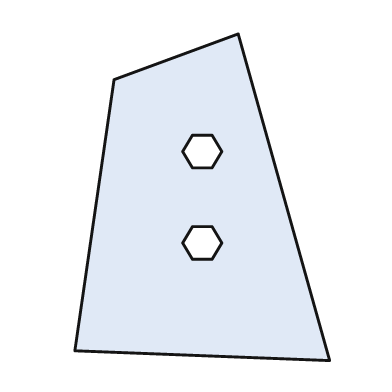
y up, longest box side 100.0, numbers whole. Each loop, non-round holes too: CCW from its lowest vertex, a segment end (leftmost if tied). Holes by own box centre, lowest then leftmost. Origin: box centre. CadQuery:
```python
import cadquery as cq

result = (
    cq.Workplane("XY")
    .moveTo(39.0, -50.0)
    .lineTo(11.0, 50.0)
    .lineTo(-27.0, 36.0)
    .lineTo(-39.0, -47.0)
    .close()
    .moveTo(-3.0, -19.0)
    .lineTo(3.0, -19.0)
    .lineTo(6.0, -14.0)
    .lineTo(3.0, -9.0)
    .lineTo(-3.0, -9.0)
    .lineTo(-6.0, -14.0)
    .close()
    .moveTo(-3.0, 9.0)
    .lineTo(3.0, 9.0)
    .lineTo(6.0, 14.0)
    .lineTo(3.0, 19.0)
    .lineTo(-3.0, 19.0)
    .lineTo(-6.0, 14.0)
    .close()
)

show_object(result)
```